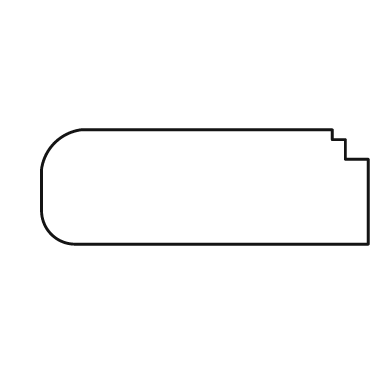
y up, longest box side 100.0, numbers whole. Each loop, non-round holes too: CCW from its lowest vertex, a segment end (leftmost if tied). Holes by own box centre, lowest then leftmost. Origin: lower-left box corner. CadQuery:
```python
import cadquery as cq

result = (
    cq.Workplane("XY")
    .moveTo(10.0, 0.0)
    .lineTo(100.0, 0.0)
    .lineTo(100.0, 26.0)
    .lineTo(93.0, 26.0)
    .lineTo(93.0, 32.0)
    .lineTo(89.0, 32.0)
    .lineTo(89.0, 35.0)
    .lineTo(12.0, 35.0)
    .threePointArc((4.0, 31.0), (0.0, 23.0))
    .lineTo(0.0, 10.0)
    .threePointArc((3.0, 3.0), (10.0, 0.0))
    .close()
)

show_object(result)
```